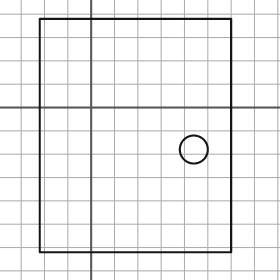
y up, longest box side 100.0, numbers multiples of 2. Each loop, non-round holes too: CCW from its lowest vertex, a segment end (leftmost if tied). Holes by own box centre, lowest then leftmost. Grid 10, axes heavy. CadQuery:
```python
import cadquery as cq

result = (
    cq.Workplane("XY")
    .moveTo(-22.0, -62.0)
    .lineTo(60.0, -62.0)
    .lineTo(60.0, 38.0)
    .lineTo(-22.0, 38.0)
    .close()
    .moveTo(44.0, -18.0)
    .circle(6.0)
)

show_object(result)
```